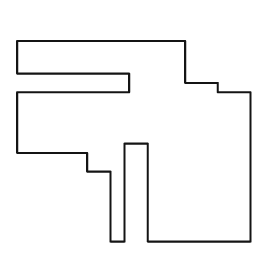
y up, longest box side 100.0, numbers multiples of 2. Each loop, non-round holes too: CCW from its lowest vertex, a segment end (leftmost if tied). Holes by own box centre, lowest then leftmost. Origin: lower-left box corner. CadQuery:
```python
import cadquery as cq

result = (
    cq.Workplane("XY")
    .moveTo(40.0, 0.0)
    .lineTo(46.0, 0.0)
    .lineTo(46.0, 42.0)
    .lineTo(56.0, 42.0)
    .lineTo(56.0, 0.0)
    .lineTo(100.0, 0.0)
    .lineTo(100.0, 64.0)
    .lineTo(86.0, 64.0)
    .lineTo(86.0, 68.0)
    .lineTo(72.0, 68.0)
    .lineTo(72.0, 86.0)
    .lineTo(0.0, 86.0)
    .lineTo(0.0, 72.0)
    .lineTo(48.0, 72.0)
    .lineTo(48.0, 64.0)
    .lineTo(0.0, 64.0)
    .lineTo(0.0, 38.0)
    .lineTo(30.0, 38.0)
    .lineTo(30.0, 30.0)
    .lineTo(40.0, 30.0)
    .close()
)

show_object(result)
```